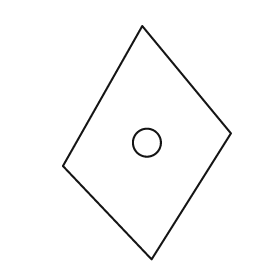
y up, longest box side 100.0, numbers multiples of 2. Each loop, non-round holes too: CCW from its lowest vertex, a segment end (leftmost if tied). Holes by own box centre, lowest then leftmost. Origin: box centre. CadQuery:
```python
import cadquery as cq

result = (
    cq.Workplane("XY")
    .moveTo(2.0, -50.0)
    .lineTo(36.0, 4.0)
    .lineTo(-2.0, 50.0)
    .lineTo(-36.0, -10.0)
    .close()
    .moveTo(0.0, 0.0)
    .circle(6.0)
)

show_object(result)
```